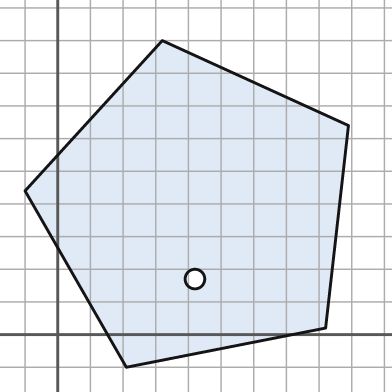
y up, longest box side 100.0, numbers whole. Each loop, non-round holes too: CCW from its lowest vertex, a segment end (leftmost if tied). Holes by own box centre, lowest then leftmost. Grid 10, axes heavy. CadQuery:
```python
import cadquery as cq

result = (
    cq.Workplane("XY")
    .moveTo(21.0, -10.0)
    .lineTo(82.0, 2.0)
    .lineTo(89.0, 64.0)
    .lineTo(32.0, 90.0)
    .lineTo(-10.0, 44.0)
    .close()
    .moveTo(42.0, 17.0)
    .circle(3.0)
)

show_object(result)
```